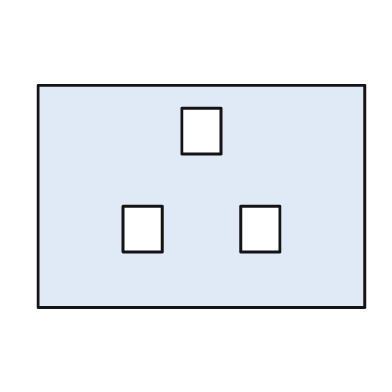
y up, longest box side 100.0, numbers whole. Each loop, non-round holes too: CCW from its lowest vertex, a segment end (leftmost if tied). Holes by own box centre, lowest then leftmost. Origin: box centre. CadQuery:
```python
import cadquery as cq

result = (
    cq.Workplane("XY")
    .moveTo(-50.0, -34.0)
    .lineTo(50.0, -34.0)
    .lineTo(50.0, 34.0)
    .lineTo(-50.0, 34.0)
    .close()
    .moveTo(-24.0, -17.0)
    .lineTo(-12.0, -17.0)
    .lineTo(-12.0, -3.0)
    .lineTo(-24.0, -3.0)
    .close()
    .moveTo(12.0, -17.0)
    .lineTo(24.0, -17.0)
    .lineTo(24.0, -3.0)
    .lineTo(12.0, -3.0)
    .close()
    .moveTo(-6.0, 13.0)
    .lineTo(6.0, 13.0)
    .lineTo(6.0, 27.0)
    .lineTo(-6.0, 27.0)
    .close()
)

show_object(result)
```